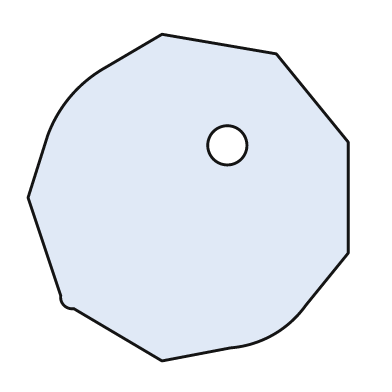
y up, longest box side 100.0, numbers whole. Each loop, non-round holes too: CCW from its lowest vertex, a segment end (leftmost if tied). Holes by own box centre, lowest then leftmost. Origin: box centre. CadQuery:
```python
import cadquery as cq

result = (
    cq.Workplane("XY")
    .moveTo(-8.0, -50.0)
    .lineTo(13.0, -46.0)
    .threePointArc((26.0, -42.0), (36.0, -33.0))
    .lineTo(49.0, -17.0)
    .lineTo(49.0, 17.0)
    .lineTo(27.0, 44.0)
    .lineTo(-8.0, 50.0)
    .lineTo(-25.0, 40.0)
    .threePointArc((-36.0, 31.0), (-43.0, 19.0))
    .lineTo(-49.0, 0.0)
    .lineTo(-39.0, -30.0)
    .threePointArc((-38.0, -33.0), (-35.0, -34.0))
    .close()
    .moveTo(12.0, 16.0)
    .circle(6.0)
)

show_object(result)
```